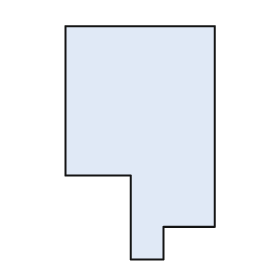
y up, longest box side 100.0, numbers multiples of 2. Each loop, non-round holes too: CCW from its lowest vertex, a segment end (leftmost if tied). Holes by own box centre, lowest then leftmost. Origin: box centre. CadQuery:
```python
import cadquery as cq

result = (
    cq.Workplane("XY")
    .moveTo(-4.0, -50.0)
    .lineTo(10.0, -50.0)
    .lineTo(10.0, -36.0)
    .lineTo(32.0, -36.0)
    .lineTo(32.0, 50.0)
    .lineTo(-32.0, 50.0)
    .lineTo(-32.0, -14.0)
    .lineTo(-4.0, -14.0)
    .close()
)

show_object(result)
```